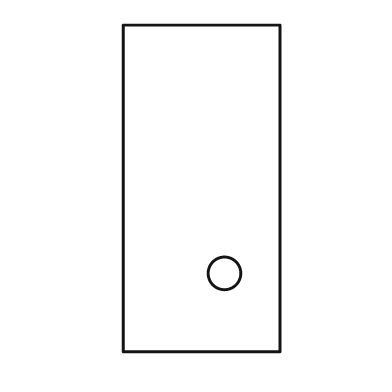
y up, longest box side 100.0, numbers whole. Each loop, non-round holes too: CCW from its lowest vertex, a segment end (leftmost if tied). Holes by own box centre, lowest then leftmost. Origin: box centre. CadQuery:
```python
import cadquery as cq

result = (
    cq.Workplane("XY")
    .moveTo(-24.0, -50.0)
    .lineTo(24.0, -50.0)
    .lineTo(24.0, 50.0)
    .lineTo(-24.0, 50.0)
    .close()
    .moveTo(7.0, -26.0)
    .circle(5.0)
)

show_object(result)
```